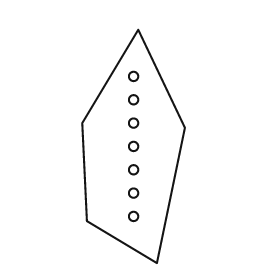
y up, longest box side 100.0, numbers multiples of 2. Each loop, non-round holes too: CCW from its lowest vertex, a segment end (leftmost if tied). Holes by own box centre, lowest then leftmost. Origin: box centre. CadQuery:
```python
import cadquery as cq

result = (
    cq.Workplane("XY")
    .moveTo(10.0, -50.0)
    .lineTo(22.0, 8.0)
    .lineTo(2.0, 50.0)
    .lineTo(-22.0, 10.0)
    .lineTo(-20.0, -32.0)
    .close()
    .moveTo(0.0, -30.0)
    .circle(2.0)
    .moveTo(0.0, -20.0)
    .circle(2.0)
    .moveTo(0.0, -10.0)
    .circle(2.0)
    .moveTo(0.0, 0.0)
    .circle(2.0)
    .moveTo(0.0, 10.0)
    .circle(2.0)
    .moveTo(0.0, 20.0)
    .circle(2.0)
    .moveTo(0.0, 30.0)
    .circle(2.0)
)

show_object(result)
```